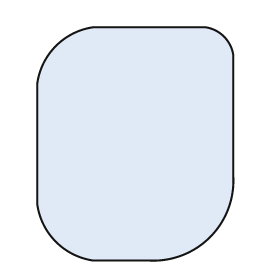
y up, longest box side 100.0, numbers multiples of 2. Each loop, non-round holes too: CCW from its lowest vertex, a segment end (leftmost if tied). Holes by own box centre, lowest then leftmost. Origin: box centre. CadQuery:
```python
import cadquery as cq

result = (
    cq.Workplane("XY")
    .moveTo(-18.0, -50.0)
    .lineTo(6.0, -50.0)
    .threePointArc((32.0, -40.0), (42.0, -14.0))
    .lineTo(42.0, 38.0)
    .threePointArc((38.0, 46.0), (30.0, 50.0))
    .lineTo(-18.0, 50.0)
    .threePointArc((-34.0, 42.0), (-42.0, 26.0))
    .lineTo(-42.0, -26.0)
    .threePointArc((-34.0, -42.0), (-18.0, -50.0))
    .close()
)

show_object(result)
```